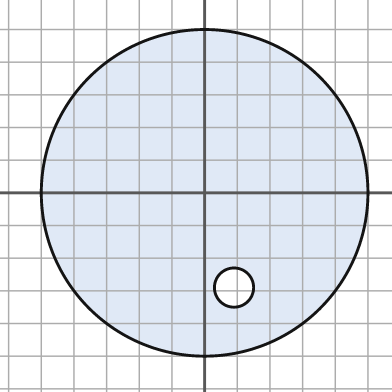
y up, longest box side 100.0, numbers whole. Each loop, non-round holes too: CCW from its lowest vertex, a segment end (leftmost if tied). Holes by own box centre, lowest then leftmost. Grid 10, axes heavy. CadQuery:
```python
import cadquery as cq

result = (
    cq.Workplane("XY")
    .moveTo(0.0, 0.0)
    .circle(50.0)
    .moveTo(9.0, -29.0)
    .circle(6.0)
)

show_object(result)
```